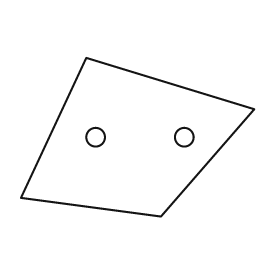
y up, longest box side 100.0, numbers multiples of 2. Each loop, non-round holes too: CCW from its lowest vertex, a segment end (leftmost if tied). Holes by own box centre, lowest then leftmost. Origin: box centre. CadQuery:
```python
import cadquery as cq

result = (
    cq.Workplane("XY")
    .moveTo(10.0, -34.0)
    .lineTo(50.0, 12.0)
    .lineTo(-22.0, 34.0)
    .lineTo(-50.0, -26.0)
    .close()
    .moveTo(-18.0, 0.0)
    .circle(4.0)
    .moveTo(20.0, 0.0)
    .circle(4.0)
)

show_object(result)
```